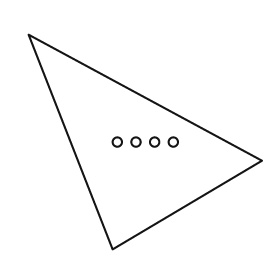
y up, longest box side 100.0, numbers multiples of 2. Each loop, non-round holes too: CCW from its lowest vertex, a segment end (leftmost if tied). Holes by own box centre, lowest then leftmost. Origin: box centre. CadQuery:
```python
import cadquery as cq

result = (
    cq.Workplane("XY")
    .moveTo(-14.0, -46.0)
    .lineTo(50.0, -8.0)
    .lineTo(-50.0, 46.0)
    .close()
    .moveTo(-12.0, 0.0)
    .circle(2.0)
    .moveTo(-4.0, 0.0)
    .circle(2.0)
    .moveTo(4.0, 0.0)
    .circle(2.0)
    .moveTo(12.0, 0.0)
    .circle(2.0)
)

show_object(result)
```